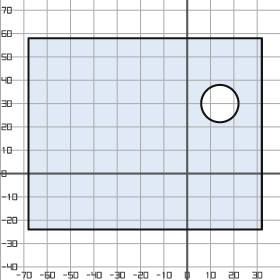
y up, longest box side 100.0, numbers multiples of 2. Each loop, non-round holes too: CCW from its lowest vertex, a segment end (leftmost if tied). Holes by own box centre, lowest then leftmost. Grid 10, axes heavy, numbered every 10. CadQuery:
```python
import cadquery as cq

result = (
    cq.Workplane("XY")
    .moveTo(-68.0, -24.0)
    .lineTo(32.0, -24.0)
    .lineTo(32.0, 58.0)
    .lineTo(-68.0, 58.0)
    .close()
    .moveTo(14.0, 30.0)
    .circle(8.0)
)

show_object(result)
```